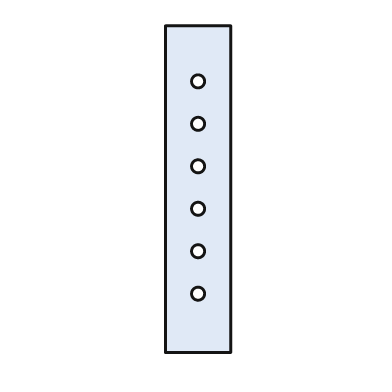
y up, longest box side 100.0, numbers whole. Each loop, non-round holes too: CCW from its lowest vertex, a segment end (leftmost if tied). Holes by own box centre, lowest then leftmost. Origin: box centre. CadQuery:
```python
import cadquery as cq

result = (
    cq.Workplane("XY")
    .moveTo(-10.0, -50.0)
    .lineTo(10.0, -50.0)
    .lineTo(10.0, 50.0)
    .lineTo(-10.0, 50.0)
    .close()
    .moveTo(0.0, -32.0)
    .circle(2.0)
    .moveTo(0.0, -19.0)
    .circle(2.0)
    .moveTo(0.0, -6.0)
    .circle(2.0)
    .moveTo(0.0, 7.0)
    .circle(2.0)
    .moveTo(0.0, 20.0)
    .circle(2.0)
    .moveTo(0.0, 33.0)
    .circle(2.0)
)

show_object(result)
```